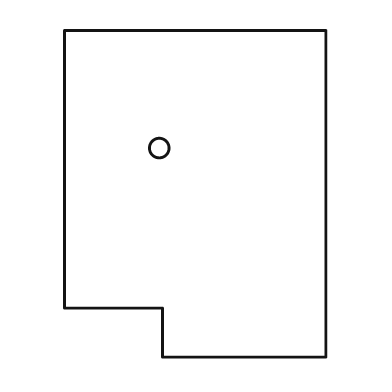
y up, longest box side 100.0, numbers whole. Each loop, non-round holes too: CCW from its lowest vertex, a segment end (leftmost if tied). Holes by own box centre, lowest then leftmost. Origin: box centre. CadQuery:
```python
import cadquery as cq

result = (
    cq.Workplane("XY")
    .moveTo(-10.0, -50.0)
    .lineTo(40.0, -50.0)
    .lineTo(40.0, 50.0)
    .lineTo(-40.0, 50.0)
    .lineTo(-40.0, -35.0)
    .lineTo(-10.0, -35.0)
    .close()
    .moveTo(-11.0, 14.0)
    .circle(3.0)
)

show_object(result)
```